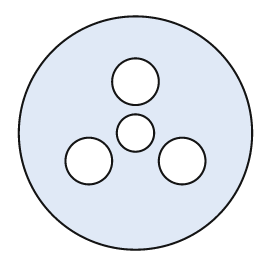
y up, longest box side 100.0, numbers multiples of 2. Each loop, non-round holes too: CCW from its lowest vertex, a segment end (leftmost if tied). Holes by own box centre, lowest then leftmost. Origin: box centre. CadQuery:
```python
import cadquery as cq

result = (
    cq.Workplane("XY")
    .moveTo(0.0, 0.0)
    .circle(50.0)
    .moveTo(-20.0, -12.0)
    .circle(10.0)
    .moveTo(20.0, -12.0)
    .circle(10.0)
    .moveTo(0.0, 0.0)
    .circle(8.0)
    .moveTo(0.0, 22.0)
    .circle(10.0)
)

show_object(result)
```